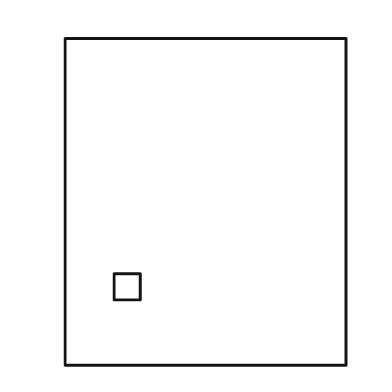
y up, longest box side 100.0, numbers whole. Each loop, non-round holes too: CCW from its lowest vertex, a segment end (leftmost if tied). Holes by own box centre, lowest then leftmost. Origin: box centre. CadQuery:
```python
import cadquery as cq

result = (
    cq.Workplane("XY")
    .moveTo(-43.0, -50.0)
    .lineTo(43.0, -50.0)
    .lineTo(43.0, 50.0)
    .lineTo(-43.0, 50.0)
    .close()
    .moveTo(-28.0, -30.0)
    .lineTo(-20.0, -30.0)
    .lineTo(-20.0, -22.0)
    .lineTo(-28.0, -22.0)
    .close()
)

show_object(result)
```